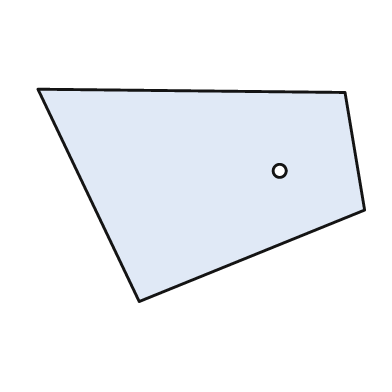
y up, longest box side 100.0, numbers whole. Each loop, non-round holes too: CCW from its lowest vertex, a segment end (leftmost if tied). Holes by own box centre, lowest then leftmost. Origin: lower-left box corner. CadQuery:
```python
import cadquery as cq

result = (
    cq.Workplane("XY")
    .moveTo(31.0, 0.0)
    .lineTo(100.0, 28.0)
    .lineTo(94.0, 64.0)
    .lineTo(0.0, 65.0)
    .close()
    .moveTo(74.0, 40.0)
    .circle(2.0)
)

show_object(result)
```